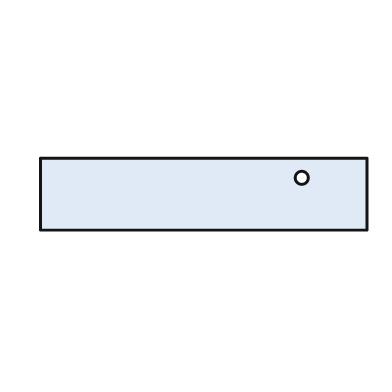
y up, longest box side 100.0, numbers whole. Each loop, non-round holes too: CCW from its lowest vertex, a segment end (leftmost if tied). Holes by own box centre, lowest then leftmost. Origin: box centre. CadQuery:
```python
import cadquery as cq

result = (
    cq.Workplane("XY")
    .moveTo(-50.0, -11.0)
    .lineTo(50.0, -11.0)
    .lineTo(50.0, 11.0)
    .lineTo(-50.0, 11.0)
    .close()
    .moveTo(30.0, 5.0)
    .circle(2.0)
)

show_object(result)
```